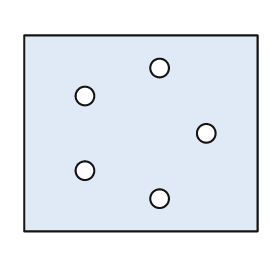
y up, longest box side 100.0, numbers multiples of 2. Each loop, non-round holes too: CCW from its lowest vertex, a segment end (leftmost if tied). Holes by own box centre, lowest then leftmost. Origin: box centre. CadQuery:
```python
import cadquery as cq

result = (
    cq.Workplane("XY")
    .moveTo(-50.0, -42.0)
    .lineTo(50.0, -42.0)
    .lineTo(50.0, 42.0)
    .lineTo(-50.0, 42.0)
    .close()
    .moveTo(8.0, -28.0)
    .circle(4.0)
    .moveTo(-24.0, -16.0)
    .circle(4.0)
    .moveTo(28.0, 0.0)
    .circle(4.0)
    .moveTo(-24.0, 16.0)
    .circle(4.0)
    .moveTo(8.0, 28.0)
    .circle(4.0)
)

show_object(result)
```